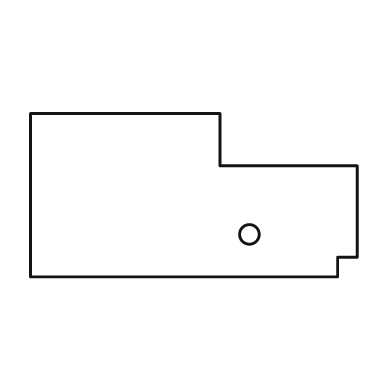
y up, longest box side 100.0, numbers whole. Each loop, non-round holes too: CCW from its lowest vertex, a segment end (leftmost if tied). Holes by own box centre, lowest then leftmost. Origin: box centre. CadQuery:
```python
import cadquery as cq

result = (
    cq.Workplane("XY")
    .moveTo(-50.0, -25.0)
    .lineTo(44.0, -25.0)
    .lineTo(44.0, -19.0)
    .lineTo(50.0, -19.0)
    .lineTo(50.0, 9.0)
    .lineTo(8.0, 9.0)
    .lineTo(8.0, 25.0)
    .lineTo(-50.0, 25.0)
    .close()
    .moveTo(17.0, -12.0)
    .circle(3.0)
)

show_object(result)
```